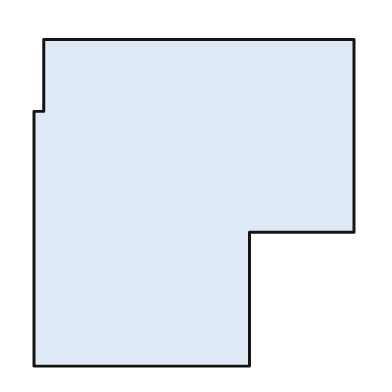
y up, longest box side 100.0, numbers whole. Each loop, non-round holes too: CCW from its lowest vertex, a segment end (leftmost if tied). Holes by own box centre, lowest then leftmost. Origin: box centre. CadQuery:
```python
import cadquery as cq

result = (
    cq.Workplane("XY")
    .moveTo(-49.0, -50.0)
    .lineTo(17.0, -50.0)
    .lineTo(17.0, -9.0)
    .lineTo(49.0, -9.0)
    .lineTo(49.0, 50.0)
    .lineTo(-46.0, 50.0)
    .lineTo(-46.0, 28.0)
    .lineTo(-49.0, 28.0)
    .close()
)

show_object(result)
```